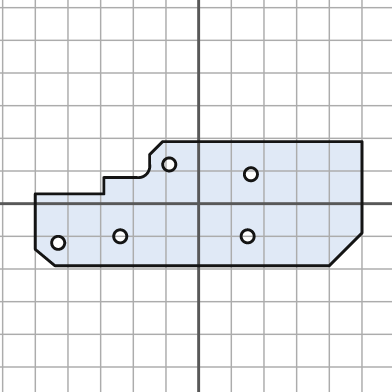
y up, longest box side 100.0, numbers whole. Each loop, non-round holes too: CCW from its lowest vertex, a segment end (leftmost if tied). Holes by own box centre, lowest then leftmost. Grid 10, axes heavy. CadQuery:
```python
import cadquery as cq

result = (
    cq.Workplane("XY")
    .moveTo(-44.0, -19.0)
    .lineTo(40.0, -19.0)
    .lineTo(50.0, -9.0)
    .lineTo(50.0, 19.0)
    .lineTo(-11.0, 19.0)
    .lineTo(-15.0, 15.0)
    .lineTo(-15.0, 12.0)
    .threePointArc((-16.0, 9.0), (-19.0, 8.0))
    .lineTo(-29.0, 8.0)
    .lineTo(-29.0, 3.0)
    .lineTo(-50.0, 3.0)
    .lineTo(-50.0, -14.0)
    .close()
    .moveTo(-43.0, -12.0)
    .circle(2.0)
    .moveTo(-24.0, -10.0)
    .circle(2.0)
    .moveTo(15.0, -10.0)
    .circle(2.0)
    .moveTo(16.0, 9.0)
    .circle(2.0)
    .moveTo(-9.0, 12.0)
    .circle(2.0)
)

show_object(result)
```